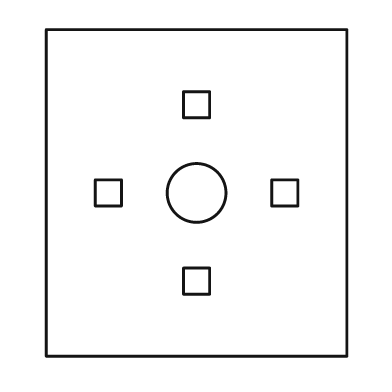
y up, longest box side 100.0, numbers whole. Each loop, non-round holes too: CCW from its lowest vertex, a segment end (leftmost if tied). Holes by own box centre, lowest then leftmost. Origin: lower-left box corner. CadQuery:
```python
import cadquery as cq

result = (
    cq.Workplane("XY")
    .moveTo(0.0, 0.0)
    .lineTo(92.0, 0.0)
    .lineTo(92.0, 100.0)
    .lineTo(0.0, 100.0)
    .close()
    .moveTo(42.0, 19.0)
    .lineTo(50.0, 19.0)
    .lineTo(50.0, 27.0)
    .lineTo(42.0, 27.0)
    .close()
    .moveTo(15.0, 46.0)
    .lineTo(23.0, 46.0)
    .lineTo(23.0, 54.0)
    .lineTo(15.0, 54.0)
    .close()
    .moveTo(46.0, 50.0)
    .circle(9.0)
    .moveTo(69.0, 46.0)
    .lineTo(77.0, 46.0)
    .lineTo(77.0, 54.0)
    .lineTo(69.0, 54.0)
    .close()
    .moveTo(42.0, 73.0)
    .lineTo(50.0, 73.0)
    .lineTo(50.0, 81.0)
    .lineTo(42.0, 81.0)
    .close()
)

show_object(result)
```